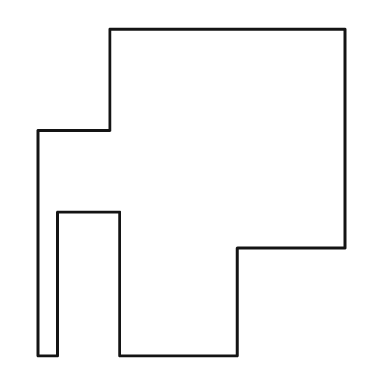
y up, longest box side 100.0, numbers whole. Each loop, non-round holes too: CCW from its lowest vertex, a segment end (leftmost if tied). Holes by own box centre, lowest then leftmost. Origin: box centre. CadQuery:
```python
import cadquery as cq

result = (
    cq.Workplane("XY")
    .moveTo(-47.0, -50.0)
    .lineTo(-41.0, -50.0)
    .lineTo(-41.0, -6.0)
    .lineTo(-22.0, -6.0)
    .lineTo(-22.0, -50.0)
    .lineTo(14.0, -50.0)
    .lineTo(14.0, -17.0)
    .lineTo(47.0, -17.0)
    .lineTo(47.0, 50.0)
    .lineTo(-25.0, 50.0)
    .lineTo(-25.0, 19.0)
    .lineTo(-47.0, 19.0)
    .close()
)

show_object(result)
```